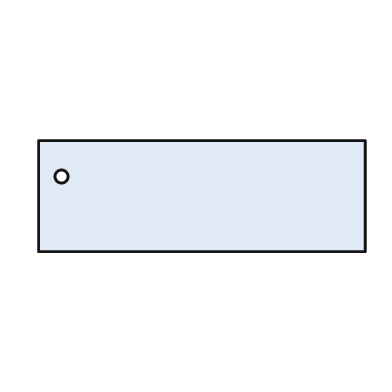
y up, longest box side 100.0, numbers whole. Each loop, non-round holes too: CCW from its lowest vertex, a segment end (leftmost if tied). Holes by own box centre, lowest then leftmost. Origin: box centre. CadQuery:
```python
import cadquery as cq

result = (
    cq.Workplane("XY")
    .moveTo(-50.0, -17.0)
    .lineTo(50.0, -17.0)
    .lineTo(50.0, 17.0)
    .lineTo(-50.0, 17.0)
    .close()
    .moveTo(-43.0, 6.0)
    .circle(2.0)
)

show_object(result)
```